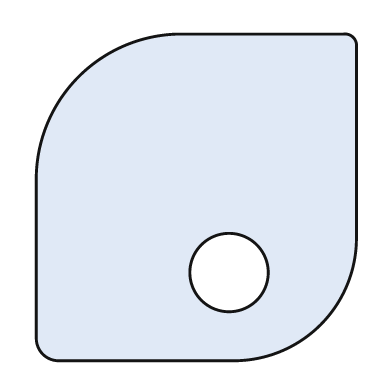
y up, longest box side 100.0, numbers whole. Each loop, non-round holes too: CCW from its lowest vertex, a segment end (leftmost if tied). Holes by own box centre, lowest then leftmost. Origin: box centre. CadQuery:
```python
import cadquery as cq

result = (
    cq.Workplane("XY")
    .moveTo(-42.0, -50.0)
    .lineTo(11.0, -50.0)
    .threePointArc((38.0, -39.0), (49.0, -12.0))
    .lineTo(49.0, 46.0)
    .threePointArc((48.0, 49.0), (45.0, 50.0))
    .lineTo(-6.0, 50.0)
    .threePointArc((-36.0, 37.0), (-49.0, 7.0))
    .lineTo(-49.0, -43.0)
    .threePointArc((-47.0, -48.0), (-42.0, -50.0))
    .close()
    .moveTo(10.0, -23.0)
    .circle(12.0)
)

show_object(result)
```